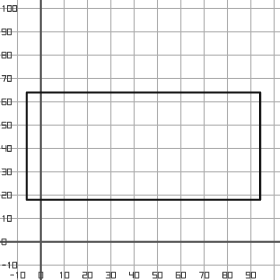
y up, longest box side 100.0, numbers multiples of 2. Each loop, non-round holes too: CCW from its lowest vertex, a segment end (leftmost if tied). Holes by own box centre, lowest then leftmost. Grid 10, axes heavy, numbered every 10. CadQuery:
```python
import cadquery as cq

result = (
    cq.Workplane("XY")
    .moveTo(-6.0, 18.0)
    .lineTo(94.0, 18.0)
    .lineTo(94.0, 64.0)
    .lineTo(-6.0, 64.0)
    .close()
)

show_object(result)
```